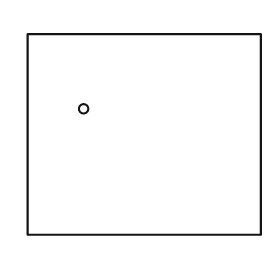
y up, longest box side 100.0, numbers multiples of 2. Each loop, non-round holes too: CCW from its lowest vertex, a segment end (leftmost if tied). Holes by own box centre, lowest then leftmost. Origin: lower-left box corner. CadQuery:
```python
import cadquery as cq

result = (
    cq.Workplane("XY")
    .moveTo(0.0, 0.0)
    .lineTo(100.0, 0.0)
    .lineTo(100.0, 86.0)
    .lineTo(0.0, 86.0)
    .close()
    .moveTo(24.0, 54.0)
    .circle(2.0)
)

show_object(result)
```